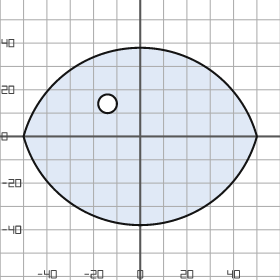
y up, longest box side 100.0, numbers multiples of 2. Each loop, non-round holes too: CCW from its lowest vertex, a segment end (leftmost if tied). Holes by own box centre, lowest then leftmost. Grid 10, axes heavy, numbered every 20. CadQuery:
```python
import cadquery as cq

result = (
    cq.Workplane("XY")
    .moveTo(-50.0, 0.0)
    .threePointArc((0.0, -38.0), (50.0, 0.0))
    .threePointArc((0.0, 38.0), (-50.0, 0.0))
    .close()
    .moveTo(-14.0, 14.0)
    .circle(4.0)
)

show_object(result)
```